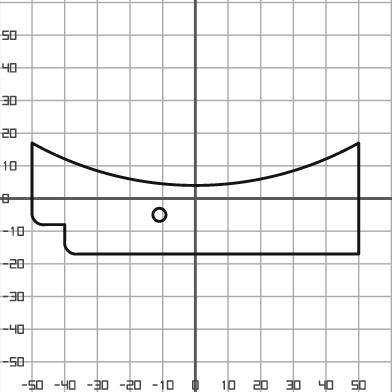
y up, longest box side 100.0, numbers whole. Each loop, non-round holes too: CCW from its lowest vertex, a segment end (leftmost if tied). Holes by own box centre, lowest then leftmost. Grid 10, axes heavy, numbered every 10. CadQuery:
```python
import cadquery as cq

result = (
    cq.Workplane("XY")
    .moveTo(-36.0, -17.0)
    .lineTo(50.0, -17.0)
    .lineTo(50.0, 17.0)
    .threePointArc((0.0, 4.0), (-50.0, 17.0))
    .lineTo(-50.0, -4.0)
    .threePointArc((-49.0, -7.0), (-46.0, -8.0))
    .lineTo(-40.0, -8.0)
    .lineTo(-40.0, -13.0)
    .threePointArc((-39.0, -16.0), (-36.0, -17.0))
    .close()
    .moveTo(-11.0, -5.0)
    .circle(2.0)
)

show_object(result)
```